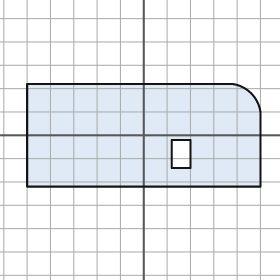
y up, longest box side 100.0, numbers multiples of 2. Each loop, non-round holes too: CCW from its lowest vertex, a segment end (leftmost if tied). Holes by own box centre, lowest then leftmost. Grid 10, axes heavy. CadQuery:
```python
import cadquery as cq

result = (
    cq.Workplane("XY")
    .moveTo(-50.0, -22.0)
    .lineTo(50.0, -22.0)
    .lineTo(50.0, 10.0)
    .threePointArc((46.0, 18.0), (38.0, 22.0))
    .lineTo(-50.0, 22.0)
    .close()
    .moveTo(12.0, -14.0)
    .lineTo(20.0, -14.0)
    .lineTo(20.0, -2.0)
    .lineTo(12.0, -2.0)
    .close()
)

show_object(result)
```